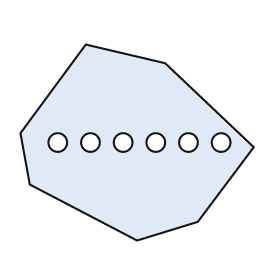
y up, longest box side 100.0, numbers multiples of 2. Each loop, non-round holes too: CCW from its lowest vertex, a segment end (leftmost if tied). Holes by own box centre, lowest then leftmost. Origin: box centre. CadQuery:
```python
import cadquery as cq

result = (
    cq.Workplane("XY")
    .moveTo(0.0, -42.0)
    .lineTo(26.0, -34.0)
    .lineTo(50.0, -2.0)
    .lineTo(12.0, 34.0)
    .lineTo(-22.0, 42.0)
    .lineTo(-50.0, 4.0)
    .lineTo(-46.0, -18.0)
    .close()
    .moveTo(-34.0, 0.0)
    .circle(4.0)
    .moveTo(-20.0, 0.0)
    .circle(4.0)
    .moveTo(-6.0, 0.0)
    .circle(4.0)
    .moveTo(8.0, 0.0)
    .circle(4.0)
    .moveTo(22.0, 0.0)
    .circle(4.0)
    .moveTo(36.0, 0.0)
    .circle(4.0)
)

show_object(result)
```